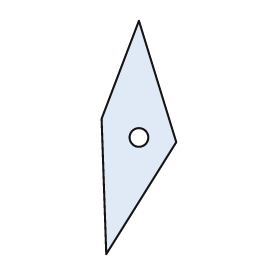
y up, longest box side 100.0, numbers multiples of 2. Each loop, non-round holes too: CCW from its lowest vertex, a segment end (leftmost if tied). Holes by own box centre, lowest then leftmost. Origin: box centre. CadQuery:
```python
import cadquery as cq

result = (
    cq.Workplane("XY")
    .moveTo(-14.0, -50.0)
    .lineTo(16.0, -2.0)
    .lineTo(0.0, 50.0)
    .lineTo(-16.0, 8.0)
    .close()
    .moveTo(0.0, 0.0)
    .circle(4.0)
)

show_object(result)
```